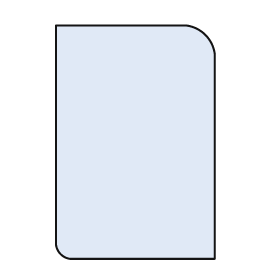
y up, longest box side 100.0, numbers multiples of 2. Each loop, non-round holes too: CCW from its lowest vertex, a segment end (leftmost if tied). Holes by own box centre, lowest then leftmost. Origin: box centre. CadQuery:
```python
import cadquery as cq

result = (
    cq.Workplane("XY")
    .moveTo(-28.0, -50.0)
    .lineTo(34.0, -50.0)
    .lineTo(34.0, 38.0)
    .threePointArc((30.0, 46.0), (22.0, 50.0))
    .lineTo(-34.0, 50.0)
    .lineTo(-34.0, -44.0)
    .threePointArc((-32.0, -48.0), (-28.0, -50.0))
    .close()
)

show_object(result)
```